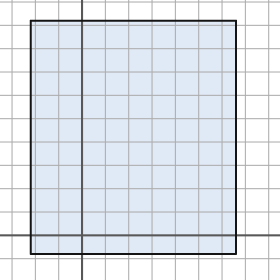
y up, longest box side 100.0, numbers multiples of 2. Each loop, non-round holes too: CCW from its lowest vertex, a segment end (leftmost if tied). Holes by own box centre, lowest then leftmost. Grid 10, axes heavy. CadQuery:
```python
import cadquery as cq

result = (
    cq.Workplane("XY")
    .moveTo(-22.0, -8.0)
    .lineTo(66.0, -8.0)
    .lineTo(66.0, 92.0)
    .lineTo(-22.0, 92.0)
    .close()
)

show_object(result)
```